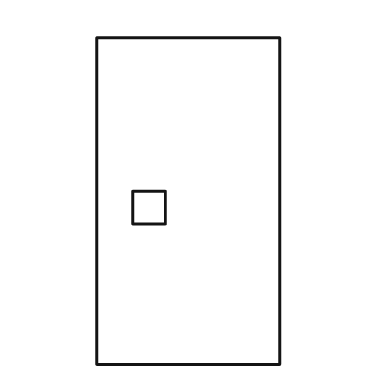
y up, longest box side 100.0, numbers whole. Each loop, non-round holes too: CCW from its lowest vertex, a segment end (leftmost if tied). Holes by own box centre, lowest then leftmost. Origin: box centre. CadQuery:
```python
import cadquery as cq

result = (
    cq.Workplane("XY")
    .moveTo(-28.0, -50.0)
    .lineTo(28.0, -50.0)
    .lineTo(28.0, 50.0)
    .lineTo(-28.0, 50.0)
    .close()
    .moveTo(-17.0, -7.0)
    .lineTo(-7.0, -7.0)
    .lineTo(-7.0, 3.0)
    .lineTo(-17.0, 3.0)
    .close()
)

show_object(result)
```